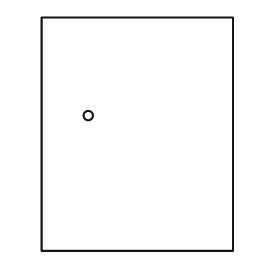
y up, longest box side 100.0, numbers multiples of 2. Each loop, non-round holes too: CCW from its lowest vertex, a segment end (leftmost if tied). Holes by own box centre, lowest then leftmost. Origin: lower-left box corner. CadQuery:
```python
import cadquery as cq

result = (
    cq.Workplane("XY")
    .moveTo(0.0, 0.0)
    .lineTo(82.0, 0.0)
    .lineTo(82.0, 100.0)
    .lineTo(0.0, 100.0)
    .close()
    .moveTo(20.0, 58.0)
    .circle(2.0)
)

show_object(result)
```